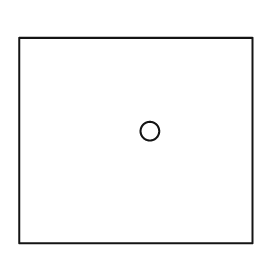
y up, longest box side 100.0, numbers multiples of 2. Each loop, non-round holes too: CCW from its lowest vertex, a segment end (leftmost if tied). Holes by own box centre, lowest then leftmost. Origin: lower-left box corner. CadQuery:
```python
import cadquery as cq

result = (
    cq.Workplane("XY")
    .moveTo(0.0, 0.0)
    .lineTo(100.0, 0.0)
    .lineTo(100.0, 88.0)
    .lineTo(0.0, 88.0)
    .close()
    .moveTo(56.0, 48.0)
    .circle(4.0)
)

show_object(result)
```